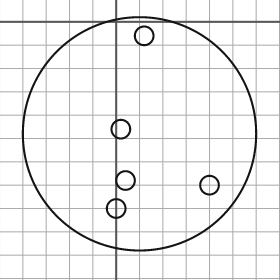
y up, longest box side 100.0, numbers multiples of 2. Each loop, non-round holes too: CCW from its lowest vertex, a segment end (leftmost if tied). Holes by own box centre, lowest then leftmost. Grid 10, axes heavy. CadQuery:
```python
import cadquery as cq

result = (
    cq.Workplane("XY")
    .moveTo(10.0, -48.0)
    .circle(50.0)
    .moveTo(0.0, -80.0)
    .circle(4.0)
    .moveTo(40.0, -70.0)
    .circle(4.0)
    .moveTo(4.0, -68.0)
    .circle(4.0)
    .moveTo(2.0, -46.0)
    .circle(4.0)
    .moveTo(12.0, -6.0)
    .circle(4.0)
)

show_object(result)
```